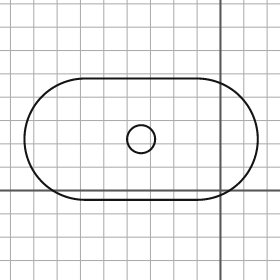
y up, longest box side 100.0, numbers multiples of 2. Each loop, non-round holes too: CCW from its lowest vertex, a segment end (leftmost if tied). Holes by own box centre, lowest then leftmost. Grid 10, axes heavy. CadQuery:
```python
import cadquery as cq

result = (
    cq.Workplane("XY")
    .moveTo(-58.0, -4.0)
    .lineTo(-10.0, -4.0)
    .threePointArc((16.0, 22.0), (-10.0, 48.0))
    .lineTo(-58.0, 48.0)
    .threePointArc((-84.0, 22.0), (-58.0, -4.0))
    .close()
    .moveTo(-34.0, 22.0)
    .circle(6.0)
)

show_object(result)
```